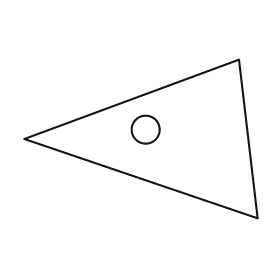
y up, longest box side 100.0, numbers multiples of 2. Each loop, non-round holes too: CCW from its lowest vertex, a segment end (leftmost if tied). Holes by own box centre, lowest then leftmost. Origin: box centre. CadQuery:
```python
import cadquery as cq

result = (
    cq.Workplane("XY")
    .moveTo(50.0, -34.0)
    .lineTo(42.0, 34.0)
    .lineTo(-50.0, 0.0)
    .close()
    .moveTo(2.0, 4.0)
    .circle(6.0)
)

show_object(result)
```